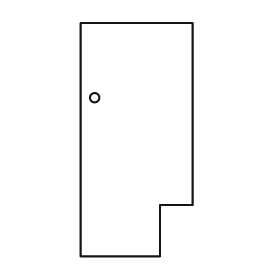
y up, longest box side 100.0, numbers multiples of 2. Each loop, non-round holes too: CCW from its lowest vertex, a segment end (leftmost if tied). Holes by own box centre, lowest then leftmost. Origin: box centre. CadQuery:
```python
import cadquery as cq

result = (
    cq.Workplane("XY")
    .moveTo(-24.0, -50.0)
    .lineTo(10.0, -50.0)
    .lineTo(10.0, -28.0)
    .lineTo(24.0, -28.0)
    .lineTo(24.0, 50.0)
    .lineTo(-24.0, 50.0)
    .close()
    .moveTo(-18.0, 18.0)
    .circle(2.0)
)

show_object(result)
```